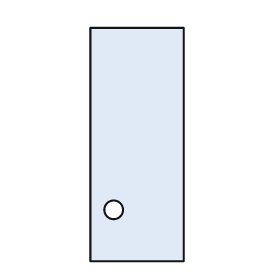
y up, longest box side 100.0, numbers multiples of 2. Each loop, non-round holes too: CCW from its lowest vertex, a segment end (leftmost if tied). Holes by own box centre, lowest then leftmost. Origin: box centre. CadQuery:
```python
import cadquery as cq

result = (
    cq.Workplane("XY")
    .moveTo(-20.0, -50.0)
    .lineTo(20.0, -50.0)
    .lineTo(20.0, 50.0)
    .lineTo(-20.0, 50.0)
    .close()
    .moveTo(-10.0, -28.0)
    .circle(4.0)
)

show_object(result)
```